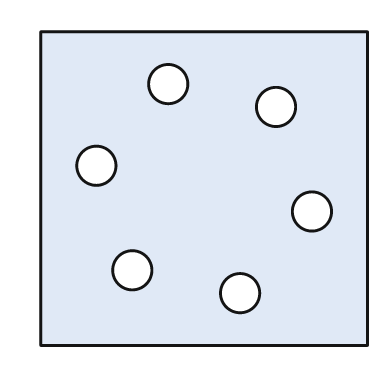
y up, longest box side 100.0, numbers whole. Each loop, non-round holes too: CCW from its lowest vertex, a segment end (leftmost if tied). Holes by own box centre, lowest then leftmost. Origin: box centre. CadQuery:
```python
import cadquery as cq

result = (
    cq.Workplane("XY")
    .moveTo(-50.0, -48.0)
    .lineTo(50.0, -48.0)
    .lineTo(50.0, 48.0)
    .lineTo(-50.0, 48.0)
    .close()
    .moveTo(11.0, -32.0)
    .circle(6.0)
    .moveTo(-22.0, -25.0)
    .circle(6.0)
    .moveTo(33.0, -7.0)
    .circle(6.0)
    .moveTo(-33.0, 7.0)
    .circle(6.0)
    .moveTo(22.0, 25.0)
    .circle(6.0)
    .moveTo(-11.0, 32.0)
    .circle(6.0)
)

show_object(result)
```